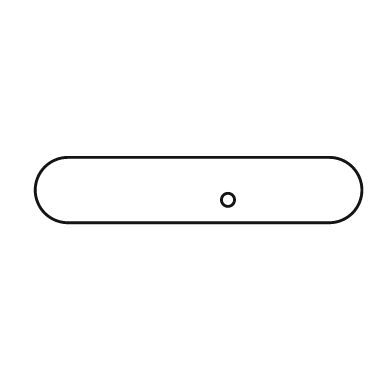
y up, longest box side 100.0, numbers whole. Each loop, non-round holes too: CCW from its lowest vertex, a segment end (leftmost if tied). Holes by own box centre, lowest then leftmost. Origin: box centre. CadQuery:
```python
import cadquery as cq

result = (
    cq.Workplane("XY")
    .moveTo(-40.0, -10.0)
    .lineTo(40.0, -10.0)
    .threePointArc((50.0, 0.0), (40.0, 10.0))
    .lineTo(-40.0, 10.0)
    .threePointArc((-50.0, 0.0), (-40.0, -10.0))
    .close()
    .moveTo(9.0, -3.0)
    .circle(2.0)
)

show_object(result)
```